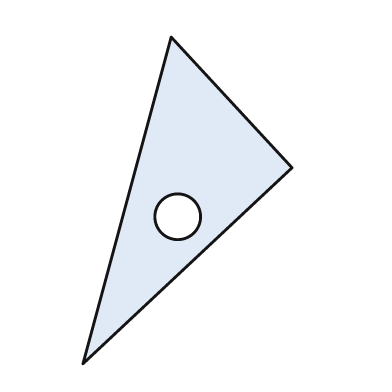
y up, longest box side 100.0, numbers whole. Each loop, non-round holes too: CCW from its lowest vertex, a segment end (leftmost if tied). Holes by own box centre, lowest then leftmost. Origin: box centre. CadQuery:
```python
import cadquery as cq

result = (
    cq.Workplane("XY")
    .moveTo(-32.0, -50.0)
    .lineTo(32.0, 10.0)
    .lineTo(-5.0, 50.0)
    .close()
    .moveTo(-3.0, -5.0)
    .circle(7.0)
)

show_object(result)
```